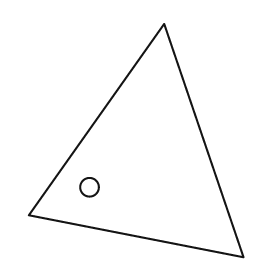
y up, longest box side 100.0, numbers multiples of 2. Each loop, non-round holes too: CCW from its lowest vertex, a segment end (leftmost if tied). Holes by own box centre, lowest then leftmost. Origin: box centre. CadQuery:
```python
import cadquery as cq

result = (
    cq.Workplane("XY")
    .moveTo(46.0, -50.0)
    .lineTo(12.0, 50.0)
    .lineTo(-46.0, -32.0)
    .close()
    .moveTo(-20.0, -20.0)
    .circle(4.0)
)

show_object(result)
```